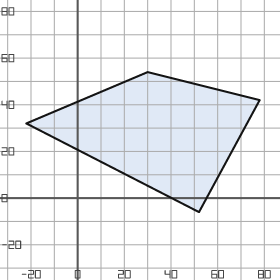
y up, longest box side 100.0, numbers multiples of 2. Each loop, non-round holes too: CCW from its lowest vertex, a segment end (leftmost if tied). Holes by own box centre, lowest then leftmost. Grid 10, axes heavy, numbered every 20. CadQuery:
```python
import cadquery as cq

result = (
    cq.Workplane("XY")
    .moveTo(52.0, -6.0)
    .lineTo(78.0, 42.0)
    .lineTo(30.0, 54.0)
    .lineTo(-22.0, 32.0)
    .close()
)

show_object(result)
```